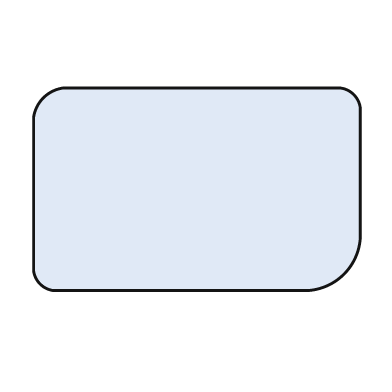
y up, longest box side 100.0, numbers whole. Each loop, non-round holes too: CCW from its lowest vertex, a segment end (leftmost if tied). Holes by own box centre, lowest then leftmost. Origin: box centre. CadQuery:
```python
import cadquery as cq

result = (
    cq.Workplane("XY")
    .moveTo(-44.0, -31.0)
    .lineTo(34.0, -31.0)
    .threePointArc((45.0, -26.0), (50.0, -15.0))
    .lineTo(50.0, 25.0)
    .threePointArc((48.0, 29.0), (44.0, 31.0))
    .lineTo(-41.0, 31.0)
    .threePointArc((-47.0, 28.0), (-50.0, 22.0))
    .lineTo(-50.0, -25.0)
    .threePointArc((-48.0, -29.0), (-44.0, -31.0))
    .close()
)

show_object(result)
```